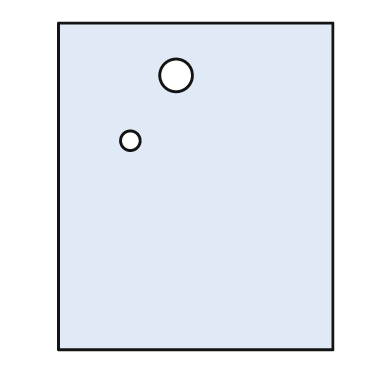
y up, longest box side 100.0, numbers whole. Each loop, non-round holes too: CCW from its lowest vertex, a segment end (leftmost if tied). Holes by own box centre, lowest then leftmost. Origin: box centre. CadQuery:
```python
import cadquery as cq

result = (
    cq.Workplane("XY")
    .moveTo(-42.0, -50.0)
    .lineTo(42.0, -50.0)
    .lineTo(42.0, 50.0)
    .lineTo(-42.0, 50.0)
    .close()
    .moveTo(-20.0, 14.0)
    .circle(3.0)
    .moveTo(-6.0, 34.0)
    .circle(5.0)
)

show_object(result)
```